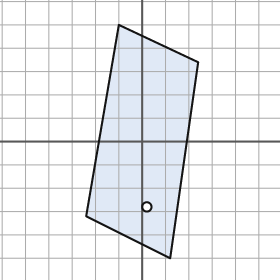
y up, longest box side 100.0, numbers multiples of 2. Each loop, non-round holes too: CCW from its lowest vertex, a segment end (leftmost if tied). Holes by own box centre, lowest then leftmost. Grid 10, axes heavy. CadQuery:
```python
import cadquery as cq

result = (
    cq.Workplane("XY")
    .moveTo(12.0, -50.0)
    .lineTo(24.0, 34.0)
    .lineTo(-10.0, 50.0)
    .lineTo(-24.0, -32.0)
    .close()
    .moveTo(2.0, -28.0)
    .circle(2.0)
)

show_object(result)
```